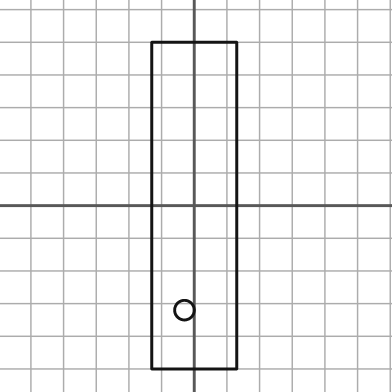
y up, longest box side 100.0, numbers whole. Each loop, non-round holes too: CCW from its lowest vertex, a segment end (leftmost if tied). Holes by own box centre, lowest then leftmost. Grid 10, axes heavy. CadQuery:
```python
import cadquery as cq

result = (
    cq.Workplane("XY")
    .moveTo(-13.0, -50.0)
    .lineTo(13.0, -50.0)
    .lineTo(13.0, 50.0)
    .lineTo(-13.0, 50.0)
    .close()
    .moveTo(-3.0, -32.0)
    .circle(3.0)
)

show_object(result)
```